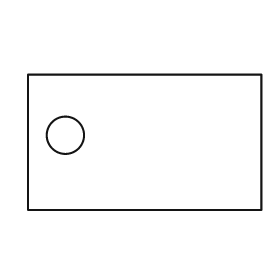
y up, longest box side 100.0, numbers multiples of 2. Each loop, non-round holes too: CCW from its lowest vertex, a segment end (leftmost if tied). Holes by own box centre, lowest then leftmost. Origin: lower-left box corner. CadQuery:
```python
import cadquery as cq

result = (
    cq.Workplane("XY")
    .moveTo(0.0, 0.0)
    .lineTo(100.0, 0.0)
    .lineTo(100.0, 58.0)
    .lineTo(0.0, 58.0)
    .close()
    .moveTo(16.0, 32.0)
    .circle(8.0)
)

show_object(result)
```